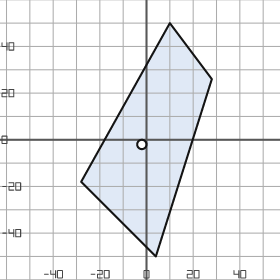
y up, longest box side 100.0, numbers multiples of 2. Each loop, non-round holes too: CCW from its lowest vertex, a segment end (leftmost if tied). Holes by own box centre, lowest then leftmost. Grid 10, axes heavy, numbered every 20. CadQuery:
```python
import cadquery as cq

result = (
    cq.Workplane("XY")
    .moveTo(4.0, -50.0)
    .lineTo(28.0, 26.0)
    .lineTo(10.0, 50.0)
    .lineTo(-28.0, -18.0)
    .close()
    .moveTo(-2.0, -2.0)
    .circle(2.0)
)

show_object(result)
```